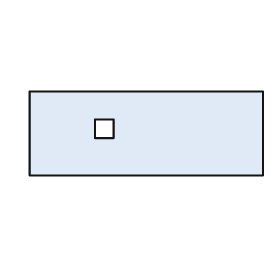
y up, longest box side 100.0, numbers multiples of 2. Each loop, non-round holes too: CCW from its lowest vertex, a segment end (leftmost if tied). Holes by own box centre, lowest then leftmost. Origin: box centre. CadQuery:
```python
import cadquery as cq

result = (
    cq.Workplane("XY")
    .moveTo(-50.0, -18.0)
    .lineTo(50.0, -18.0)
    .lineTo(50.0, 18.0)
    .lineTo(-50.0, 18.0)
    .close()
    .moveTo(-22.0, -2.0)
    .lineTo(-14.0, -2.0)
    .lineTo(-14.0, 6.0)
    .lineTo(-22.0, 6.0)
    .close()
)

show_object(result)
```